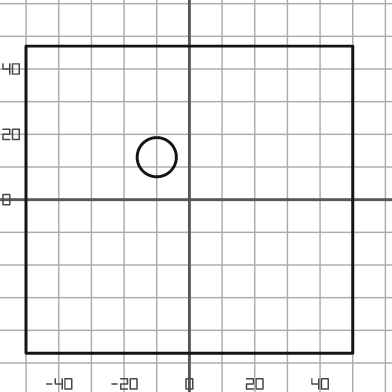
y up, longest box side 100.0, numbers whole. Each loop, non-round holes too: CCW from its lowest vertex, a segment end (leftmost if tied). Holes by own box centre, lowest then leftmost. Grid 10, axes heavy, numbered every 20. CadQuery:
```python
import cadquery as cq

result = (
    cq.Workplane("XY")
    .moveTo(-50.0, -47.0)
    .lineTo(50.0, -47.0)
    .lineTo(50.0, 47.0)
    .lineTo(-50.0, 47.0)
    .close()
    .moveTo(-10.0, 13.0)
    .circle(6.0)
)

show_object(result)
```